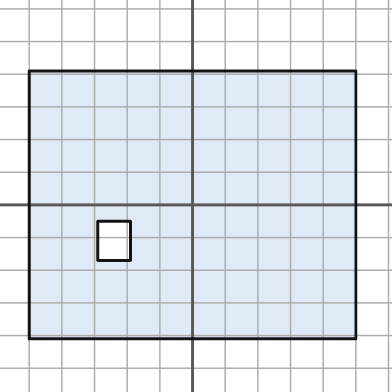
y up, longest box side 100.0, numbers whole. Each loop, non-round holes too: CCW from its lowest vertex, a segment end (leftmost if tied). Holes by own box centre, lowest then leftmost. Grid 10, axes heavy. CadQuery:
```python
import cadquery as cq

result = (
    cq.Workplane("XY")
    .moveTo(-50.0, -41.0)
    .lineTo(50.0, -41.0)
    .lineTo(50.0, 41.0)
    .lineTo(-50.0, 41.0)
    .close()
    .moveTo(-29.0, -17.0)
    .lineTo(-19.0, -17.0)
    .lineTo(-19.0, -5.0)
    .lineTo(-29.0, -5.0)
    .close()
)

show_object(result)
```